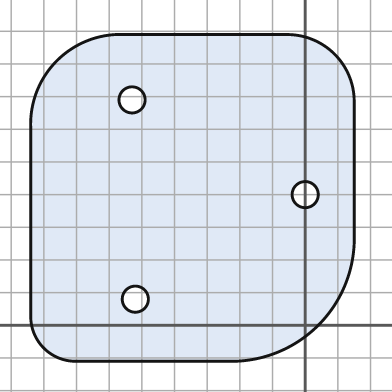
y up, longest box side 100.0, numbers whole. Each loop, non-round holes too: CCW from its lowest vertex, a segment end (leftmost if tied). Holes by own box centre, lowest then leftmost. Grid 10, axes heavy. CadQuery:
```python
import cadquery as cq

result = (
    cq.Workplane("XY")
    .moveTo(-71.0, -11.0)
    .lineTo(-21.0, -11.0)
    .threePointArc((4.0, 0.0), (15.0, 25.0))
    .lineTo(15.0, 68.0)
    .threePointArc((9.0, 83.0), (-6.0, 89.0))
    .lineTo(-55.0, 89.0)
    .threePointArc((-76.0, 81.0), (-84.0, 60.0))
    .lineTo(-84.0, 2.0)
    .threePointArc((-80.0, -7.0), (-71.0, -11.0))
    .close()
    .moveTo(-52.0, 8.0)
    .circle(4.0)
    .moveTo(0.0, 40.0)
    .circle(4.0)
    .moveTo(-53.0, 69.0)
    .circle(4.0)
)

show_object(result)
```